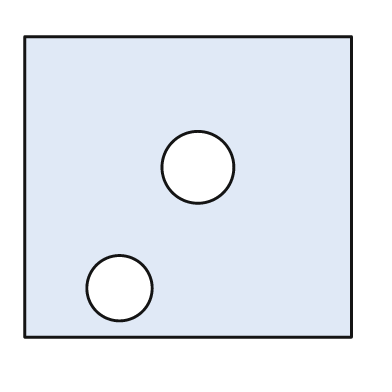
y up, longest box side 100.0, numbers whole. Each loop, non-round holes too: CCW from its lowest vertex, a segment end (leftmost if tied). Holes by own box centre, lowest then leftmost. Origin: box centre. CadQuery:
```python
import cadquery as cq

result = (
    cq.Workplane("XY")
    .moveTo(-50.0, -46.0)
    .lineTo(50.0, -46.0)
    .lineTo(50.0, 46.0)
    .lineTo(-50.0, 46.0)
    .close()
    .moveTo(-21.0, -31.0)
    .circle(10.0)
    .moveTo(3.0, 6.0)
    .circle(11.0)
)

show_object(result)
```